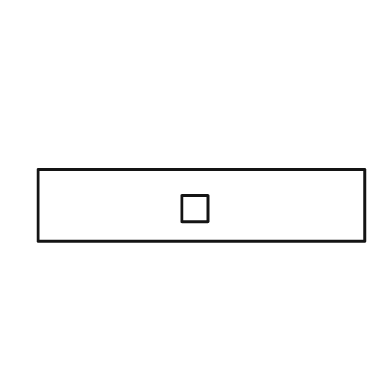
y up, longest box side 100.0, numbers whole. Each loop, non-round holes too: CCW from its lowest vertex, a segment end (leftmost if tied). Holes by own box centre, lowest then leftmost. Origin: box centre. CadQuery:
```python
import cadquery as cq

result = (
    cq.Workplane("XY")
    .moveTo(-50.0, -11.0)
    .lineTo(50.0, -11.0)
    .lineTo(50.0, 11.0)
    .lineTo(-50.0, 11.0)
    .close()
    .moveTo(-6.0, -5.0)
    .lineTo(2.0, -5.0)
    .lineTo(2.0, 3.0)
    .lineTo(-6.0, 3.0)
    .close()
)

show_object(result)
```